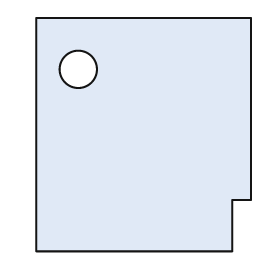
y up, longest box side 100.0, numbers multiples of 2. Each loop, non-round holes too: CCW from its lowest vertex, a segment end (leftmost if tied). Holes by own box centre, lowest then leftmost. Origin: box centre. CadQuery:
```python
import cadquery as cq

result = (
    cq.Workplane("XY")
    .moveTo(-46.0, -50.0)
    .lineTo(38.0, -50.0)
    .lineTo(38.0, -28.0)
    .lineTo(46.0, -28.0)
    .lineTo(46.0, 50.0)
    .lineTo(-46.0, 50.0)
    .close()
    .moveTo(-28.0, 28.0)
    .circle(8.0)
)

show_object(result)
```